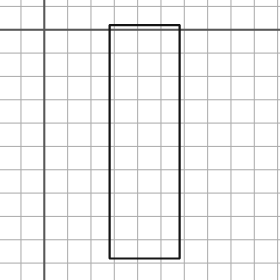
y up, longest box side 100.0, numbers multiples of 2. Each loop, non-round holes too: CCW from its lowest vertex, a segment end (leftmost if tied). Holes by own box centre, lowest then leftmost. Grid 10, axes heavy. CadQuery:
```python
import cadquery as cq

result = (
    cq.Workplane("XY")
    .moveTo(28.0, -98.0)
    .lineTo(58.0, -98.0)
    .lineTo(58.0, 2.0)
    .lineTo(28.0, 2.0)
    .close()
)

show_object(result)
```